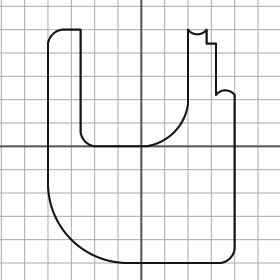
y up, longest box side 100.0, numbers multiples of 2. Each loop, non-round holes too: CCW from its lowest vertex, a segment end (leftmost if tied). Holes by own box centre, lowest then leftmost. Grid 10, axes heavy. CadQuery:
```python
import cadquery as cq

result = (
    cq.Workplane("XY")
    .moveTo(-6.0, -50.0)
    .lineTo(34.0, -50.0)
    .threePointArc((38.0, -48.0), (40.0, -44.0))
    .lineTo(40.0, 22.0)
    .threePointArc((36.0, 24.0), (32.0, 22.0))
    .lineTo(32.0, 44.0)
    .lineTo(28.0, 44.0)
    .lineTo(28.0, 50.0)
    .threePointArc((24.0, 48.0), (20.0, 50.0))
    .lineTo(20.0, 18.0)
    .threePointArc((14.0, 6.0), (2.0, 0.0))
    .lineTo(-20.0, 0.0)
    .threePointArc((-24.0, 2.0), (-26.0, 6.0))
    .lineTo(-26.0, 50.0)
    .lineTo(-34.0, 50.0)
    .threePointArc((-38.0, 48.0), (-40.0, 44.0))
    .lineTo(-40.0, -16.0)
    .threePointArc((-30.0, -40.0), (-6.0, -50.0))
    .close()
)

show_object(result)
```